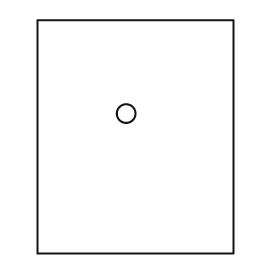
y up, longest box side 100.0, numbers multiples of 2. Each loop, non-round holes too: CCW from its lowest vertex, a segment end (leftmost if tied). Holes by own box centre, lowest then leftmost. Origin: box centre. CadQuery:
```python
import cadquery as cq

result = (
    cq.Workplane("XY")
    .moveTo(-42.0, -50.0)
    .lineTo(42.0, -50.0)
    .lineTo(42.0, 50.0)
    .lineTo(-42.0, 50.0)
    .close()
    .moveTo(-4.0, 10.0)
    .circle(4.0)
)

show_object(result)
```